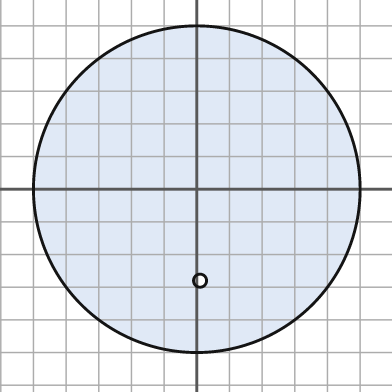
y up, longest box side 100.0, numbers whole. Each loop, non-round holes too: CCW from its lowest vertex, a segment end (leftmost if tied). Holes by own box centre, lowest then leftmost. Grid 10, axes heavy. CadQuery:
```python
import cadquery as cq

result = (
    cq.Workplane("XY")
    .moveTo(0.0, 0.0)
    .circle(50.0)
    .moveTo(1.0, -28.0)
    .circle(2.0)
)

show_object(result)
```